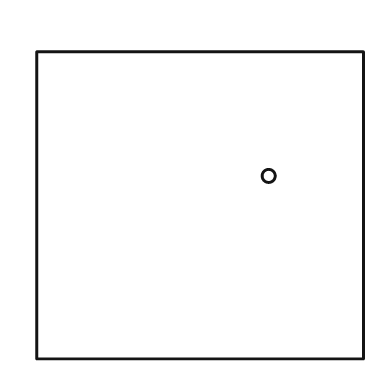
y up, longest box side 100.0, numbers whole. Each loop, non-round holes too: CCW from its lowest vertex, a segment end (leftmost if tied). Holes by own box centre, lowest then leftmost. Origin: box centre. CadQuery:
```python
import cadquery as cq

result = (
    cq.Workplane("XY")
    .moveTo(-50.0, -47.0)
    .lineTo(50.0, -47.0)
    .lineTo(50.0, 47.0)
    .lineTo(-50.0, 47.0)
    .close()
    .moveTo(21.0, 9.0)
    .circle(2.0)
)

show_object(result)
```